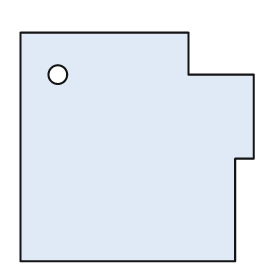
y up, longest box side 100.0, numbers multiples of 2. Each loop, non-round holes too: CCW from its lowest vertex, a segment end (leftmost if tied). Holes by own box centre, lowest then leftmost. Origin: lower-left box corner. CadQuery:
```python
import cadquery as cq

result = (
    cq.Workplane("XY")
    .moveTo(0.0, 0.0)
    .lineTo(92.0, 0.0)
    .lineTo(92.0, 44.0)
    .lineTo(100.0, 44.0)
    .lineTo(100.0, 80.0)
    .lineTo(72.0, 80.0)
    .lineTo(72.0, 98.0)
    .lineTo(0.0, 98.0)
    .close()
    .moveTo(16.0, 80.0)
    .circle(4.0)
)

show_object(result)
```